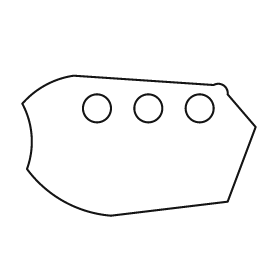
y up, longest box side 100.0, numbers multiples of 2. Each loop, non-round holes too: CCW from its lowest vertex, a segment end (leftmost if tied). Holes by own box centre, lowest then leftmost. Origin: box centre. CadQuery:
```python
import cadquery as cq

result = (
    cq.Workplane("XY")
    .moveTo(-12.0, -30.0)
    .lineTo(38.0, -24.0)
    .lineTo(50.0, 8.0)
    .lineTo(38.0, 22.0)
    .threePointArc((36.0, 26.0), (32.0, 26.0))
    .lineTo(-28.0, 30.0)
    .threePointArc((-40.0, 26.0), (-50.0, 18.0))
    .threePointArc((-46.0, 4.0), (-48.0, -10.0))
    .threePointArc((-32.0, -24.0), (-12.0, -30.0))
    .close()
    .moveTo(-18.0, 16.0)
    .circle(6.0)
    .moveTo(4.0, 16.0)
    .circle(6.0)
    .moveTo(26.0, 16.0)
    .circle(6.0)
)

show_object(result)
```